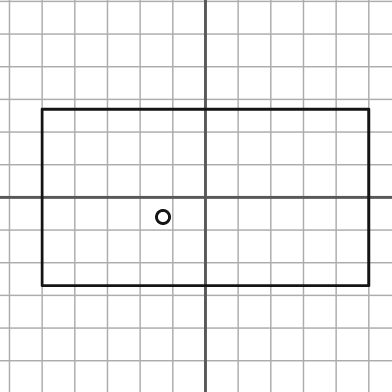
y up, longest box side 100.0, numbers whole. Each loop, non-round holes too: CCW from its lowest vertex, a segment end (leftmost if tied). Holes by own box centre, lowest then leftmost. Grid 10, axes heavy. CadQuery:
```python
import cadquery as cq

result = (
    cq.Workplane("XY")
    .moveTo(-50.0, -27.0)
    .lineTo(50.0, -27.0)
    .lineTo(50.0, 27.0)
    .lineTo(-50.0, 27.0)
    .close()
    .moveTo(-13.0, -6.0)
    .circle(2.0)
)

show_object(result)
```